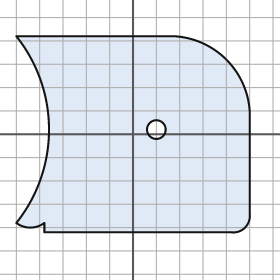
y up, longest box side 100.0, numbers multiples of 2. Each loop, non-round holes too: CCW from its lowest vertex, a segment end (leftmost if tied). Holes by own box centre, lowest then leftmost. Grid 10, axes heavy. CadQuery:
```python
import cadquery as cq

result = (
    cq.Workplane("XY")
    .moveTo(-38.0, -42.0)
    .lineTo(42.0, -42.0)
    .threePointArc((48.0, -40.0), (50.0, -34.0))
    .lineTo(50.0, 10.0)
    .threePointArc((40.0, 32.0), (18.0, 42.0))
    .lineTo(-50.0, 42.0)
    .threePointArc((-36.0, 2.0), (-50.0, -38.0))
    .threePointArc((-44.0, -40.0), (-38.0, -38.0))
    .close()
    .moveTo(10.0, 2.0)
    .circle(4.0)
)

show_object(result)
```